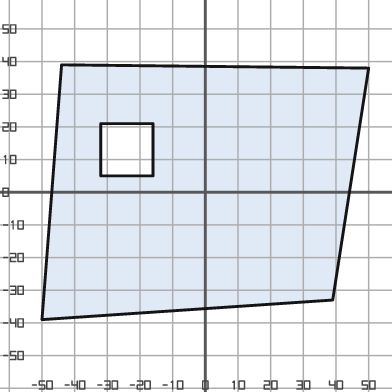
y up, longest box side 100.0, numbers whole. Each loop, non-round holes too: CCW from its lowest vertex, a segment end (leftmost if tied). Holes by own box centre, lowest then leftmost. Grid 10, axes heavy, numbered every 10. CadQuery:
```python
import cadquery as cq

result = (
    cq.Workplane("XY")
    .moveTo(-50.0, -39.0)
    .lineTo(39.0, -33.0)
    .lineTo(50.0, 38.0)
    .lineTo(-44.0, 39.0)
    .close()
    .moveTo(-32.0, 5.0)
    .lineTo(-16.0, 5.0)
    .lineTo(-16.0, 21.0)
    .lineTo(-32.0, 21.0)
    .close()
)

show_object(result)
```